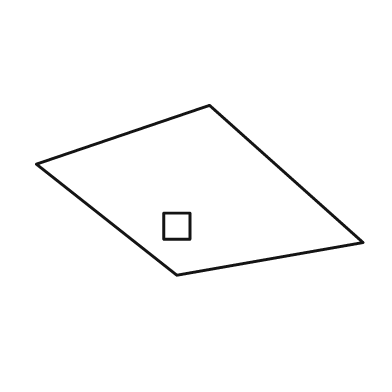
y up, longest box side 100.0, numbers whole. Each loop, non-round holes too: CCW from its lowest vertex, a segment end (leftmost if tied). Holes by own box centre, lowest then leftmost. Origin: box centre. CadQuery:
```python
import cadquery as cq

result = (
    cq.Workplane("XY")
    .moveTo(-7.0, -26.0)
    .lineTo(50.0, -16.0)
    .lineTo(3.0, 26.0)
    .lineTo(-50.0, 8.0)
    .close()
    .moveTo(-11.0, -15.0)
    .lineTo(-3.0, -15.0)
    .lineTo(-3.0, -7.0)
    .lineTo(-11.0, -7.0)
    .close()
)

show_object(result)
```